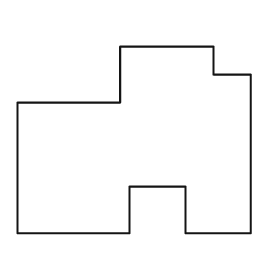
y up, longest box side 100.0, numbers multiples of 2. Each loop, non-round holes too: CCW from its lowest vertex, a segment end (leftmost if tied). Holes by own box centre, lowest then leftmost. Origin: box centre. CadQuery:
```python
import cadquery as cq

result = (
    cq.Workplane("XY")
    .moveTo(-50.0, -40.0)
    .lineTo(-2.0, -40.0)
    .lineTo(-2.0, -20.0)
    .lineTo(22.0, -20.0)
    .lineTo(22.0, -40.0)
    .lineTo(50.0, -40.0)
    .lineTo(50.0, 28.0)
    .lineTo(34.0, 28.0)
    .lineTo(34.0, 40.0)
    .lineTo(-6.0, 40.0)
    .lineTo(-6.0, 16.0)
    .lineTo(-50.0, 16.0)
    .close()
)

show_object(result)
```